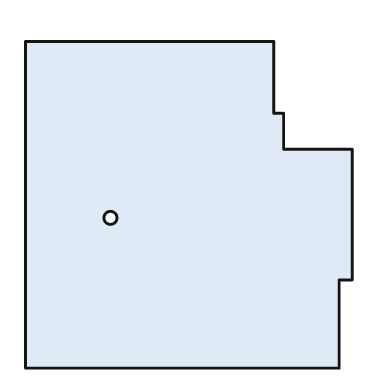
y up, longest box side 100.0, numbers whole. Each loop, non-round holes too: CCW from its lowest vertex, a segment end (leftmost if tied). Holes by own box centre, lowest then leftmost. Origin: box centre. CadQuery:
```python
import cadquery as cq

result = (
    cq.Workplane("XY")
    .moveTo(-50.0, -50.0)
    .lineTo(46.0, -50.0)
    .lineTo(46.0, -23.0)
    .lineTo(50.0, -23.0)
    .lineTo(50.0, 17.0)
    .lineTo(29.0, 17.0)
    .lineTo(29.0, 28.0)
    .lineTo(26.0, 28.0)
    .lineTo(26.0, 50.0)
    .lineTo(-50.0, 50.0)
    .close()
    .moveTo(-24.0, -4.0)
    .circle(2.0)
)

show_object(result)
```